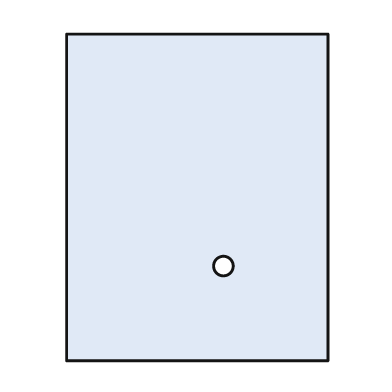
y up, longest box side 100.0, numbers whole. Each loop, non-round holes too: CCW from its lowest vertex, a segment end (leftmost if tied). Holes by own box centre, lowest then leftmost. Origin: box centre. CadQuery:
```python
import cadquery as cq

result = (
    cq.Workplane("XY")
    .moveTo(-40.0, -50.0)
    .lineTo(40.0, -50.0)
    .lineTo(40.0, 50.0)
    .lineTo(-40.0, 50.0)
    .close()
    .moveTo(8.0, -21.0)
    .circle(3.0)
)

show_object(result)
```